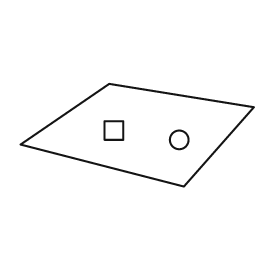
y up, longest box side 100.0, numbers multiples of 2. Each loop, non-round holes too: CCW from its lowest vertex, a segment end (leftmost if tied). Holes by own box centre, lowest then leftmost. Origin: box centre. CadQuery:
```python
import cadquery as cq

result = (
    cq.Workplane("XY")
    .moveTo(20.0, -22.0)
    .lineTo(50.0, 12.0)
    .lineTo(-12.0, 22.0)
    .lineTo(-50.0, -4.0)
    .close()
    .moveTo(18.0, -2.0)
    .circle(4.0)
    .moveTo(-14.0, -2.0)
    .lineTo(-6.0, -2.0)
    .lineTo(-6.0, 6.0)
    .lineTo(-14.0, 6.0)
    .close()
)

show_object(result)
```